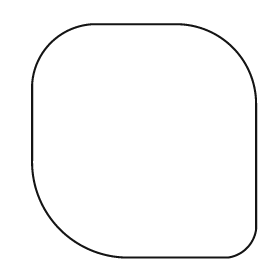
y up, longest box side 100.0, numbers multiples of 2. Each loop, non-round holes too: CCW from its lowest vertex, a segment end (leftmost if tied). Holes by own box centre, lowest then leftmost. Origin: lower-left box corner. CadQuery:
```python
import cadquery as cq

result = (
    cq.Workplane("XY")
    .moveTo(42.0, 0.0)
    .lineTo(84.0, 0.0)
    .threePointArc((92.0, 4.0), (96.0, 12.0))
    .lineTo(96.0, 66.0)
    .threePointArc((86.0, 90.0), (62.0, 100.0))
    .lineTo(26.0, 100.0)
    .threePointArc((8.0, 92.0), (0.0, 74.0))
    .lineTo(0.0, 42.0)
    .threePointArc((12.0, 12.0), (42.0, 0.0))
    .close()
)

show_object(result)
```